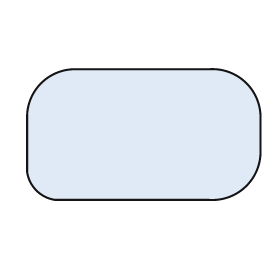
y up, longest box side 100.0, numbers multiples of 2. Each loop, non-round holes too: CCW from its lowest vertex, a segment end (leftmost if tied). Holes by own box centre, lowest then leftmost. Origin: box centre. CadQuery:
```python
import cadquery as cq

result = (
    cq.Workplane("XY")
    .moveTo(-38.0, -28.0)
    .lineTo(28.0, -28.0)
    .threePointArc((44.0, -22.0), (50.0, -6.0))
    .lineTo(50.0, 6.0)
    .threePointArc((44.0, 22.0), (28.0, 28.0))
    .lineTo(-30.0, 28.0)
    .threePointArc((-44.0, 22.0), (-50.0, 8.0))
    .lineTo(-50.0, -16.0)
    .threePointArc((-46.0, -24.0), (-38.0, -28.0))
    .close()
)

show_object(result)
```